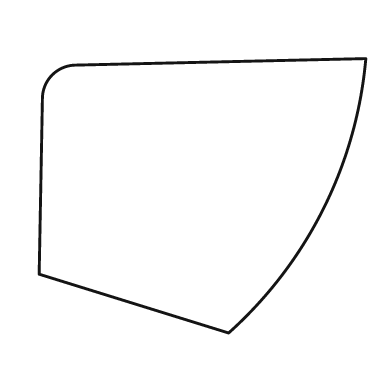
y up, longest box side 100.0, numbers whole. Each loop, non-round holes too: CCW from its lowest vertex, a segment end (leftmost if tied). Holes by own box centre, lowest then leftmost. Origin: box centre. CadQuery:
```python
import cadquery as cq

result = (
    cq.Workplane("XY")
    .moveTo(8.0, -42.0)
    .threePointArc((37.0, -4.0), (50.0, 42.0))
    .lineTo(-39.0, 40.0)
    .threePointArc((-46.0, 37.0), (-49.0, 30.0))
    .lineTo(-50.0, -24.0)
    .close()
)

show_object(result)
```